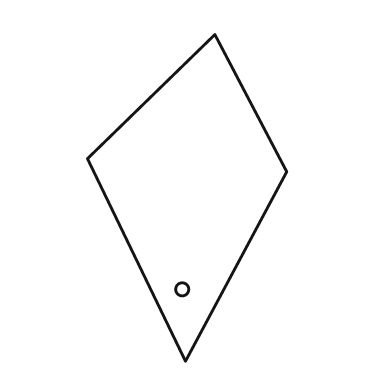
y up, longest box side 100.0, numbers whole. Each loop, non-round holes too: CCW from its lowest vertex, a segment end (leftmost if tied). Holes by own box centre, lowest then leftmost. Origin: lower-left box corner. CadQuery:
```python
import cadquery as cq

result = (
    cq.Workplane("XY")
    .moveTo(30.0, 0.0)
    .lineTo(61.0, 58.0)
    .lineTo(39.0, 100.0)
    .lineTo(0.0, 62.0)
    .close()
    .moveTo(29.0, 22.0)
    .circle(2.0)
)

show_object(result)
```